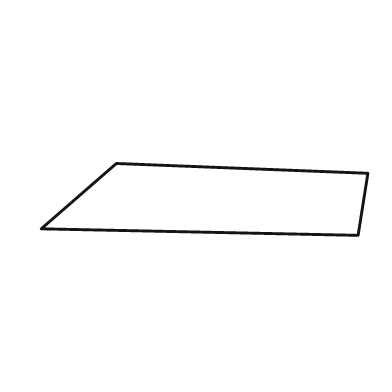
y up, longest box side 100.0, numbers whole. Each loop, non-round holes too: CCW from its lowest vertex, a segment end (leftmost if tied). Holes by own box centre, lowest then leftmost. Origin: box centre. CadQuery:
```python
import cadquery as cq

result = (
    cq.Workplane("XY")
    .moveTo(47.0, -11.0)
    .lineTo(50.0, 8.0)
    .lineTo(-27.0, 11.0)
    .lineTo(-50.0, -9.0)
    .close()
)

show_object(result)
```